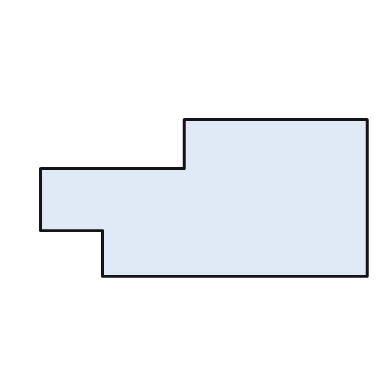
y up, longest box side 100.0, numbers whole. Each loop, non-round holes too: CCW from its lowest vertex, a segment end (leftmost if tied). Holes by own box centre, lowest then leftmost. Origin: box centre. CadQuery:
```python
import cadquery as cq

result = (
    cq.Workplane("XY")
    .moveTo(-31.0, -24.0)
    .lineTo(50.0, -24.0)
    .lineTo(50.0, 24.0)
    .lineTo(-6.0, 24.0)
    .lineTo(-6.0, 9.0)
    .lineTo(-50.0, 9.0)
    .lineTo(-50.0, -10.0)
    .lineTo(-31.0, -10.0)
    .close()
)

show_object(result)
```